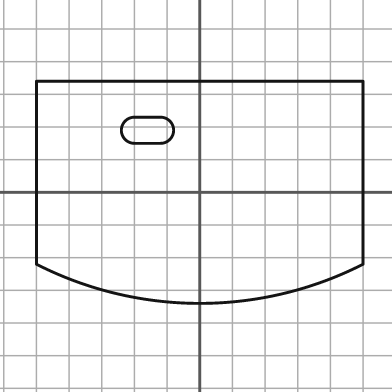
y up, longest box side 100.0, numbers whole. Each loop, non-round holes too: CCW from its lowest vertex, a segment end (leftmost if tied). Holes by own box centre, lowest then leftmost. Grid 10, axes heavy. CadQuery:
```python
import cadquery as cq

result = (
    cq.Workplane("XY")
    .moveTo(-50.0, -22.0)
    .threePointArc((0.0, -34.0), (50.0, -22.0))
    .lineTo(50.0, 34.0)
    .lineTo(-50.0, 34.0)
    .close()
    .moveTo(-20.0, 15.0)
    .lineTo(-12.0, 15.0)
    .threePointArc((-8.0, 19.0), (-12.0, 23.0))
    .lineTo(-20.0, 23.0)
    .threePointArc((-24.0, 19.0), (-20.0, 15.0))
    .close()
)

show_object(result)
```